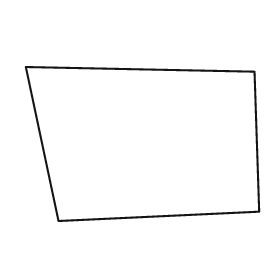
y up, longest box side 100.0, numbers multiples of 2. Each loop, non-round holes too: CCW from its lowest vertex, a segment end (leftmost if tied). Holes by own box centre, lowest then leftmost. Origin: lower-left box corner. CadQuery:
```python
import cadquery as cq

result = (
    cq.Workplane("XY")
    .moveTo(14.0, 0.0)
    .lineTo(100.0, 4.0)
    .lineTo(98.0, 64.0)
    .lineTo(0.0, 66.0)
    .close()
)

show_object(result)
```